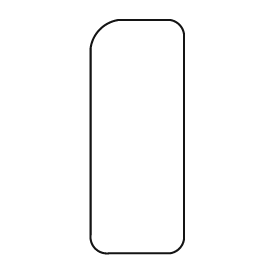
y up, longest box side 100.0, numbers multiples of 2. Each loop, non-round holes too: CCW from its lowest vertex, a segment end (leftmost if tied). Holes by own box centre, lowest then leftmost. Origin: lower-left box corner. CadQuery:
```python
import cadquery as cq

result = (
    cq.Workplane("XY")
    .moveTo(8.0, 0.0)
    .lineTo(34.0, 0.0)
    .threePointArc((38.0, 2.0), (40.0, 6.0))
    .lineTo(40.0, 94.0)
    .threePointArc((38.0, 98.0), (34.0, 100.0))
    .lineTo(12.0, 100.0)
    .threePointArc((4.0, 96.0), (0.0, 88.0))
    .lineTo(0.0, 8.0)
    .threePointArc((2.0, 2.0), (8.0, 0.0))
    .close()
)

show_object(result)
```